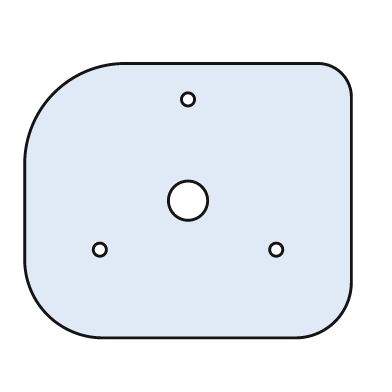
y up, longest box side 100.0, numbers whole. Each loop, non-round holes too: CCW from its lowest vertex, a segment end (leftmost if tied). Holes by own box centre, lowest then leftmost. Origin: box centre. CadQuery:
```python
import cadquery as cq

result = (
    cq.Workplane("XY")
    .moveTo(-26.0, -42.0)
    .lineTo(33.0, -42.0)
    .threePointArc((45.0, -37.0), (50.0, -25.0))
    .lineTo(50.0, 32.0)
    .threePointArc((47.0, 39.0), (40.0, 42.0))
    .lineTo(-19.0, 42.0)
    .threePointArc((-41.0, 33.0), (-50.0, 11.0))
    .lineTo(-50.0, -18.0)
    .threePointArc((-43.0, -35.0), (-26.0, -42.0))
    .close()
    .moveTo(-27.0, -15.0)
    .circle(2.0)
    .moveTo(27.0, -15.0)
    .circle(2.0)
    .moveTo(0.0, 0.0)
    .circle(6.0)
    .moveTo(0.0, 31.0)
    .circle(2.0)
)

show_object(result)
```